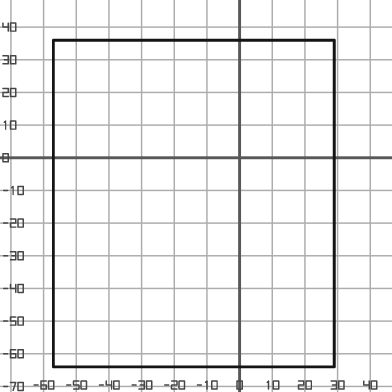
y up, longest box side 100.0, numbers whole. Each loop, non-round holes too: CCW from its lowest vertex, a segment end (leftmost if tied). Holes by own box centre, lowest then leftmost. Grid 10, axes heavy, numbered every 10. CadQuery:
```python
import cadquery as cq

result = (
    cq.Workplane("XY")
    .moveTo(-57.0, -64.0)
    .lineTo(29.0, -64.0)
    .lineTo(29.0, 36.0)
    .lineTo(-57.0, 36.0)
    .close()
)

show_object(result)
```